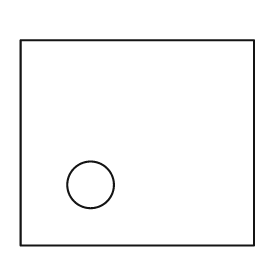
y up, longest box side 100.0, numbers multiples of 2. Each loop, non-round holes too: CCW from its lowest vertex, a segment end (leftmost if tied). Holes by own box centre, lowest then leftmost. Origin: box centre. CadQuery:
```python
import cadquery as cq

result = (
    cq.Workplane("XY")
    .moveTo(-50.0, -44.0)
    .lineTo(50.0, -44.0)
    .lineTo(50.0, 44.0)
    .lineTo(-50.0, 44.0)
    .close()
    .moveTo(-20.0, -18.0)
    .circle(10.0)
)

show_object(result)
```